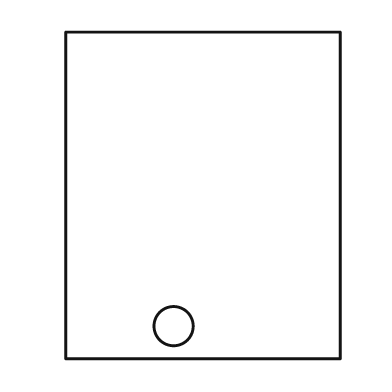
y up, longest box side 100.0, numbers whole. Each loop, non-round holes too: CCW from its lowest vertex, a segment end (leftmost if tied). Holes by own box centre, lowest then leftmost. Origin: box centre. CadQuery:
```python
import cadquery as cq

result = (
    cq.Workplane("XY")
    .moveTo(-42.0, -50.0)
    .lineTo(42.0, -50.0)
    .lineTo(42.0, 50.0)
    .lineTo(-42.0, 50.0)
    .close()
    .moveTo(-9.0, -40.0)
    .circle(6.0)
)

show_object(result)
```